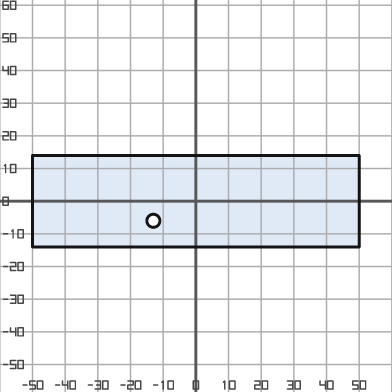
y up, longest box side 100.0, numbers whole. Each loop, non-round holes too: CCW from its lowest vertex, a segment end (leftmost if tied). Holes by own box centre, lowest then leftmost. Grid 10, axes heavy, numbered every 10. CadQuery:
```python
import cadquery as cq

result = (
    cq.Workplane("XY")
    .moveTo(-50.0, -14.0)
    .lineTo(50.0, -14.0)
    .lineTo(50.0, 14.0)
    .lineTo(-50.0, 14.0)
    .close()
    .moveTo(-13.0, -6.0)
    .circle(2.0)
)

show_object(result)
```